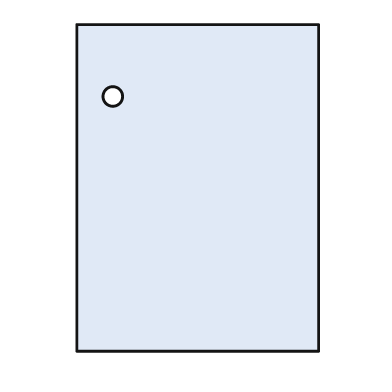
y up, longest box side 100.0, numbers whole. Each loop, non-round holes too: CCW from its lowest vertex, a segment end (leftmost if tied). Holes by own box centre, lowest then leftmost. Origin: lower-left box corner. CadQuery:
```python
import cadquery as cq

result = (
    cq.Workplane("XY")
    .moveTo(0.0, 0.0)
    .lineTo(74.0, 0.0)
    .lineTo(74.0, 100.0)
    .lineTo(0.0, 100.0)
    .close()
    .moveTo(11.0, 78.0)
    .circle(3.0)
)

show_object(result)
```